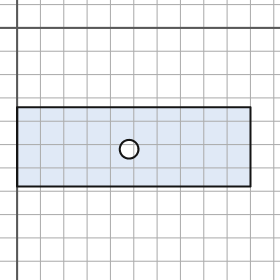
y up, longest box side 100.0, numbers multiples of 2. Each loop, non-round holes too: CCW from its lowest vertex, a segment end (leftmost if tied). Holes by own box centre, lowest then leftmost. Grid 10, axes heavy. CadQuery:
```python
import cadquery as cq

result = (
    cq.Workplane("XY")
    .moveTo(0.0, -68.0)
    .lineTo(100.0, -68.0)
    .lineTo(100.0, -34.0)
    .lineTo(0.0, -34.0)
    .close()
    .moveTo(48.0, -52.0)
    .circle(4.0)
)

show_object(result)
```